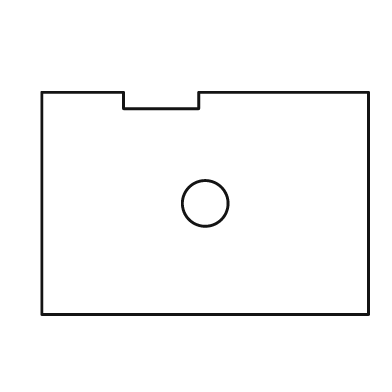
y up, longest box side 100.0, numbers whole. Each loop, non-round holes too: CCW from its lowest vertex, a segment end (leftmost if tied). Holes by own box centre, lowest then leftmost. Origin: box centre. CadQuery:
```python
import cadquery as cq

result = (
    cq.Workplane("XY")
    .moveTo(-50.0, -34.0)
    .lineTo(50.0, -34.0)
    .lineTo(50.0, 34.0)
    .lineTo(-2.0, 34.0)
    .lineTo(-2.0, 29.0)
    .lineTo(-25.0, 29.0)
    .lineTo(-25.0, 34.0)
    .lineTo(-50.0, 34.0)
    .close()
    .moveTo(0.0, 0.0)
    .circle(7.0)
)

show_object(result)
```